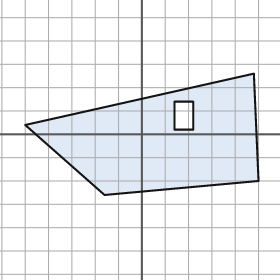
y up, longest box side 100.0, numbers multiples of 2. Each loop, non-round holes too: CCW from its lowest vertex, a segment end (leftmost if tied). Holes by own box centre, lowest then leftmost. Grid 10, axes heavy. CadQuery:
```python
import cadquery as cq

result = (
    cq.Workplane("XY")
    .moveTo(-16.0, -26.0)
    .lineTo(50.0, -20.0)
    .lineTo(48.0, 26.0)
    .lineTo(-50.0, 4.0)
    .close()
    .moveTo(14.0, 2.0)
    .lineTo(22.0, 2.0)
    .lineTo(22.0, 14.0)
    .lineTo(14.0, 14.0)
    .close()
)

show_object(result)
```